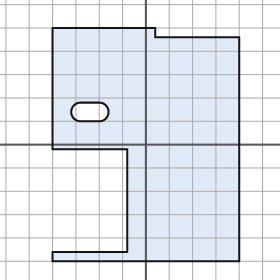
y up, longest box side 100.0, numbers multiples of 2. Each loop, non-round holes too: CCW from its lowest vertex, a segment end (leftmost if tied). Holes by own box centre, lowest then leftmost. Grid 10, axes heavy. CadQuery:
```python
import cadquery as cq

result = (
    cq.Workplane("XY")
    .moveTo(-40.0, -50.0)
    .lineTo(40.0, -50.0)
    .lineTo(40.0, 46.0)
    .lineTo(4.0, 46.0)
    .lineTo(4.0, 50.0)
    .lineTo(-40.0, 50.0)
    .lineTo(-40.0, -2.0)
    .lineTo(-8.0, -2.0)
    .lineTo(-8.0, -46.0)
    .lineTo(-40.0, -46.0)
    .close()
    .moveTo(-28.0, 10.0)
    .lineTo(-20.0, 10.0)
    .threePointArc((-16.0, 14.0), (-20.0, 18.0))
    .lineTo(-28.0, 18.0)
    .threePointArc((-32.0, 14.0), (-28.0, 10.0))
    .close()
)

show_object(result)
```